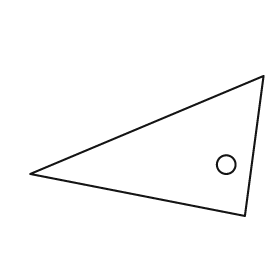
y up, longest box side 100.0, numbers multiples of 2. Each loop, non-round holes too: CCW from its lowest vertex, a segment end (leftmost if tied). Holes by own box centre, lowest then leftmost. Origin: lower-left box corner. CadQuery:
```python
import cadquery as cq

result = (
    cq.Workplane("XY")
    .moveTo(92.0, 0.0)
    .lineTo(100.0, 60.0)
    .lineTo(0.0, 18.0)
    .close()
    .moveTo(84.0, 22.0)
    .circle(4.0)
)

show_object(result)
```